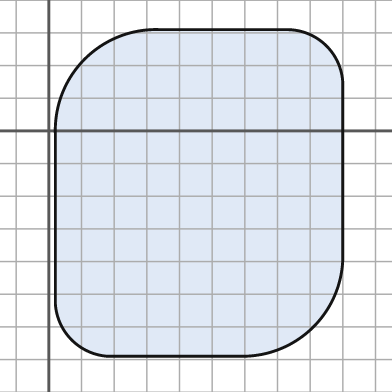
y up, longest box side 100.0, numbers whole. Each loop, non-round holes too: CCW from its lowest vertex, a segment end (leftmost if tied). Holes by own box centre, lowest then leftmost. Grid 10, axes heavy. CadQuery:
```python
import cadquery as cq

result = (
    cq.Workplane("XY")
    .moveTo(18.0, -69.0)
    .lineTo(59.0, -69.0)
    .threePointArc((81.0, -60.0), (90.0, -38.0))
    .lineTo(90.0, 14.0)
    .threePointArc((85.0, 26.0), (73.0, 31.0))
    .lineTo(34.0, 31.0)
    .threePointArc((11.0, 22.0), (2.0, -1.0))
    .lineTo(2.0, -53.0)
    .threePointArc((7.0, -64.0), (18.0, -69.0))
    .close()
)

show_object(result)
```